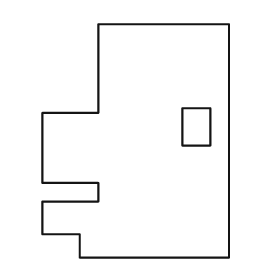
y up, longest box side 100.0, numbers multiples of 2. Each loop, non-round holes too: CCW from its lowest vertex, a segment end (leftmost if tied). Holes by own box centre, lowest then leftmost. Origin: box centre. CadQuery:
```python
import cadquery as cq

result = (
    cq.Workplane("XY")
    .moveTo(-24.0, -50.0)
    .lineTo(40.0, -50.0)
    .lineTo(40.0, 50.0)
    .lineTo(-16.0, 50.0)
    .lineTo(-16.0, 12.0)
    .lineTo(-40.0, 12.0)
    .lineTo(-40.0, -18.0)
    .lineTo(-16.0, -18.0)
    .lineTo(-16.0, -26.0)
    .lineTo(-40.0, -26.0)
    .lineTo(-40.0, -40.0)
    .lineTo(-24.0, -40.0)
    .close()
    .moveTo(20.0, -2.0)
    .lineTo(32.0, -2.0)
    .lineTo(32.0, 14.0)
    .lineTo(20.0, 14.0)
    .close()
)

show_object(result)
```